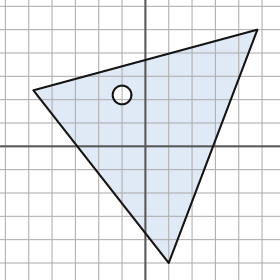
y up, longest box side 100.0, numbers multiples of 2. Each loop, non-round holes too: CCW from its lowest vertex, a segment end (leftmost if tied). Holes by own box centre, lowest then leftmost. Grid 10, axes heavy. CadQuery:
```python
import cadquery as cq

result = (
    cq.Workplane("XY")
    .moveTo(10.0, -50.0)
    .lineTo(48.0, 50.0)
    .lineTo(-48.0, 24.0)
    .close()
    .moveTo(-10.0, 22.0)
    .circle(4.0)
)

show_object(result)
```